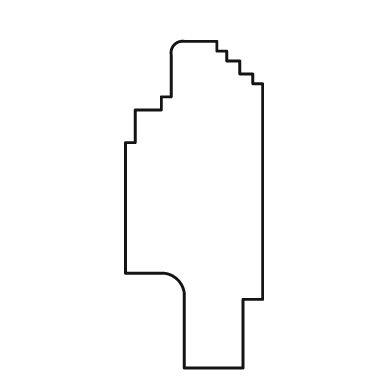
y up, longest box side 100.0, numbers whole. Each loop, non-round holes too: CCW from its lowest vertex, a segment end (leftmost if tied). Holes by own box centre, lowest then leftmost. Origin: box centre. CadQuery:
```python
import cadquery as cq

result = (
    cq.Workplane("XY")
    .moveTo(-3.0, -50.0)
    .lineTo(15.0, -50.0)
    .lineTo(15.0, -29.0)
    .lineTo(21.0, -29.0)
    .lineTo(21.0, 37.0)
    .lineTo(18.0, 37.0)
    .lineTo(18.0, 40.0)
    .lineTo(14.0, 40.0)
    .lineTo(14.0, 44.0)
    .lineTo(10.0, 44.0)
    .lineTo(10.0, 47.0)
    .lineTo(7.0, 47.0)
    .lineTo(7.0, 50.0)
    .lineTo(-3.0, 50.0)
    .threePointArc((-6.0, 49.0), (-7.0, 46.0))
    .lineTo(-7.0, 33.0)
    .lineTo(-10.0, 33.0)
    .lineTo(-10.0, 29.0)
    .lineTo(-18.0, 29.0)
    .lineTo(-18.0, 19.0)
    .lineTo(-21.0, 19.0)
    .lineTo(-21.0, -21.0)
    .lineTo(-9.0, -21.0)
    .threePointArc((-5.0, -23.0), (-3.0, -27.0))
    .close()
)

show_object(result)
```